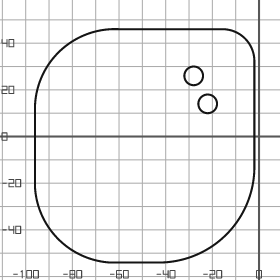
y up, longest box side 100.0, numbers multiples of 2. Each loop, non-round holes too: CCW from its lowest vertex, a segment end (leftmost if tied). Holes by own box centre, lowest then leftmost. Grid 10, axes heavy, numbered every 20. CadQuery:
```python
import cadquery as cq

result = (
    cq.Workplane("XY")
    .moveTo(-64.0, -54.0)
    .lineTo(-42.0, -54.0)
    .threePointArc((-14.0, -42.0), (-2.0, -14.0))
    .lineTo(-2.0, 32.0)
    .threePointArc((-6.0, 42.0), (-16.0, 46.0))
    .lineTo(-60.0, 46.0)
    .threePointArc((-86.0, 36.0), (-96.0, 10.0))
    .lineTo(-96.0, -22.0)
    .threePointArc((-86.0, -44.0), (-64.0, -54.0))
    .close()
    .moveTo(-22.0, 14.0)
    .circle(4.0)
    .moveTo(-28.0, 26.0)
    .circle(4.0)
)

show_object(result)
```